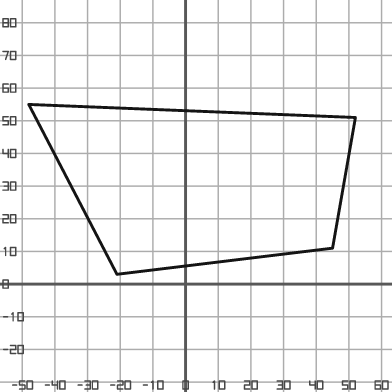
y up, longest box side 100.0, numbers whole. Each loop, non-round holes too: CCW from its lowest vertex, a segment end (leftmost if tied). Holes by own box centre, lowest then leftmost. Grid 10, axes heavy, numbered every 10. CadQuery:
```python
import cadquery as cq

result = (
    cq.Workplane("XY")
    .moveTo(-21.0, 3.0)
    .lineTo(45.0, 11.0)
    .lineTo(52.0, 51.0)
    .lineTo(-48.0, 55.0)
    .close()
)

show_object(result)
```